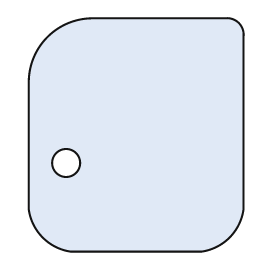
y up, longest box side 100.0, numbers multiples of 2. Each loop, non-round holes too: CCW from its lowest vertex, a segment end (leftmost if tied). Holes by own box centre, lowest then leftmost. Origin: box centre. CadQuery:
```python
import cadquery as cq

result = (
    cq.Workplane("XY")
    .moveTo(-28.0, -50.0)
    .lineTo(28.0, -50.0)
    .threePointArc((40.0, -44.0), (46.0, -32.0))
    .lineTo(46.0, 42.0)
    .threePointArc((44.0, 48.0), (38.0, 50.0))
    .lineTo(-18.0, 50.0)
    .threePointArc((-38.0, 42.0), (-46.0, 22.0))
    .lineTo(-46.0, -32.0)
    .threePointArc((-40.0, -44.0), (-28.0, -50.0))
    .close()
    .moveTo(-30.0, -12.0)
    .circle(6.0)
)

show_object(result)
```